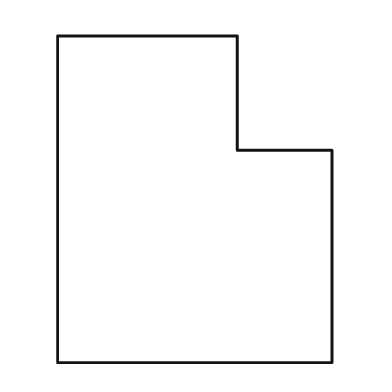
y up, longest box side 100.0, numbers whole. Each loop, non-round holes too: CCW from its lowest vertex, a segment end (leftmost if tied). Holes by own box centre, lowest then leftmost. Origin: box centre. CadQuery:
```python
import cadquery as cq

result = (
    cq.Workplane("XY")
    .moveTo(-42.0, -50.0)
    .lineTo(42.0, -50.0)
    .lineTo(42.0, 15.0)
    .lineTo(13.0, 15.0)
    .lineTo(13.0, 50.0)
    .lineTo(-42.0, 50.0)
    .close()
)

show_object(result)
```